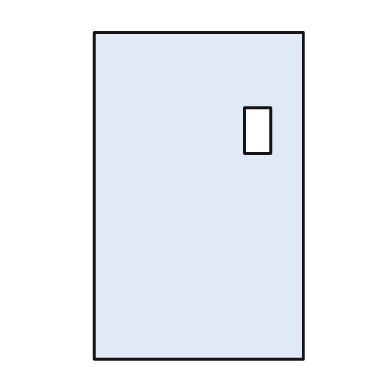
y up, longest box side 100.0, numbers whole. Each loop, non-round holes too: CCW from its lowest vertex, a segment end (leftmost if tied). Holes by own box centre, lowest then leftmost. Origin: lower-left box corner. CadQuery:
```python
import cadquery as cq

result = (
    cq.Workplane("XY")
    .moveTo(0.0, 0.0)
    .lineTo(64.0, 0.0)
    .lineTo(64.0, 100.0)
    .lineTo(0.0, 100.0)
    .close()
    .moveTo(46.0, 63.0)
    .lineTo(54.0, 63.0)
    .lineTo(54.0, 77.0)
    .lineTo(46.0, 77.0)
    .close()
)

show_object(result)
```